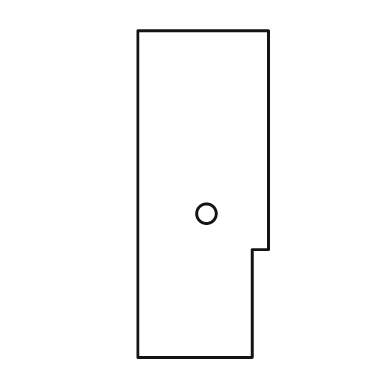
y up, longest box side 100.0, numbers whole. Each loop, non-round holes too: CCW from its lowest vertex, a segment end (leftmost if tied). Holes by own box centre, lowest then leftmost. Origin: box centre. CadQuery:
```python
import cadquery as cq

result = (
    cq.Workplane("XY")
    .moveTo(-20.0, -50.0)
    .lineTo(15.0, -50.0)
    .lineTo(15.0, -17.0)
    .lineTo(20.0, -17.0)
    .lineTo(20.0, 50.0)
    .lineTo(-20.0, 50.0)
    .close()
    .moveTo(1.0, -6.0)
    .circle(3.0)
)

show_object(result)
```